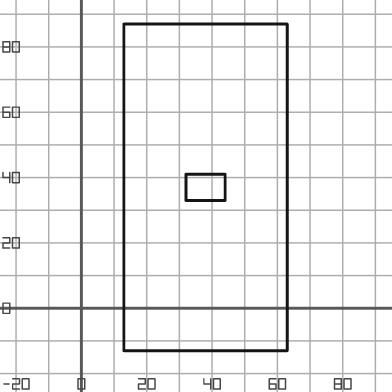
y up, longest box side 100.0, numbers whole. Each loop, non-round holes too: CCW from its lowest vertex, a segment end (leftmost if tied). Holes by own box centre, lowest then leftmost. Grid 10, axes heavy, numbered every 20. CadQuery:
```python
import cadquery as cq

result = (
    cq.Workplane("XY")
    .moveTo(13.0, -13.0)
    .lineTo(63.0, -13.0)
    .lineTo(63.0, 87.0)
    .lineTo(13.0, 87.0)
    .close()
    .moveTo(32.0, 33.0)
    .lineTo(44.0, 33.0)
    .lineTo(44.0, 41.0)
    .lineTo(32.0, 41.0)
    .close()
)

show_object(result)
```